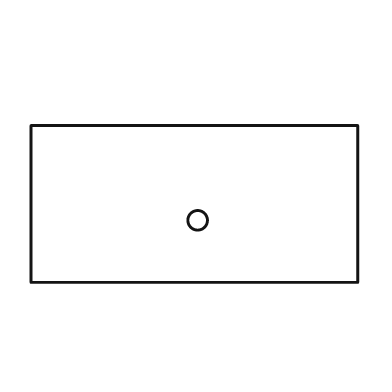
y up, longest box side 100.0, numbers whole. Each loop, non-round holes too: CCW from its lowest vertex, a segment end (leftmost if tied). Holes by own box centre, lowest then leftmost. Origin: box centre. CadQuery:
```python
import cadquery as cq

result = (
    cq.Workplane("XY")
    .moveTo(-50.0, -24.0)
    .lineTo(50.0, -24.0)
    .lineTo(50.0, 24.0)
    .lineTo(-50.0, 24.0)
    .close()
    .moveTo(1.0, -5.0)
    .circle(3.0)
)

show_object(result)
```